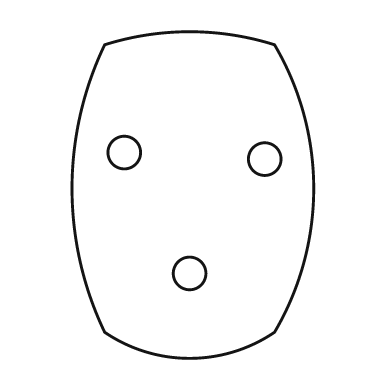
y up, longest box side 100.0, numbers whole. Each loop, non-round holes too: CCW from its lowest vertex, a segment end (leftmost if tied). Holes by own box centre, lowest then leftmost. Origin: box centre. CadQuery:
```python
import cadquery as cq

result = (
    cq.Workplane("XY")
    .moveTo(-27.0, -42.0)
    .threePointArc((-1.0, -50.0), (25.0, -42.0))
    .threePointArc((37.0, 2.0), (25.0, 46.0))
    .threePointArc((-1.0, 50.0), (-27.0, 46.0))
    .threePointArc((-37.0, 2.0), (-27.0, -42.0))
    .close()
    .moveTo(-1.0, -24.0)
    .circle(5.0)
    .moveTo(22.0, 11.0)
    .circle(5.0)
    .moveTo(-21.0, 13.0)
    .circle(5.0)
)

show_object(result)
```